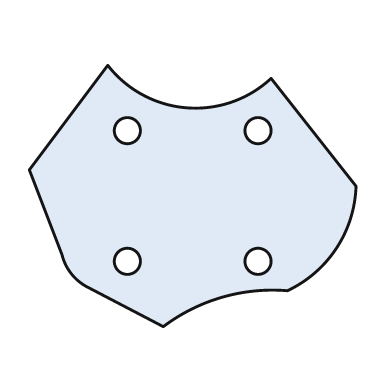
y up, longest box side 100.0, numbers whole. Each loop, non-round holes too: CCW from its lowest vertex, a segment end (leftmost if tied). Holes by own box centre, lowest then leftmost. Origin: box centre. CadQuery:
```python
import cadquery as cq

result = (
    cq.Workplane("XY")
    .moveTo(-9.0, -40.0)
    .threePointArc((9.0, -31.0), (29.0, -29.0))
    .threePointArc((44.0, -16.0), (50.0, 3.0))
    .lineTo(24.0, 36.0)
    .threePointArc((-2.0, 27.0), (-26.0, 40.0))
    .lineTo(-50.0, 8.0)
    .lineTo(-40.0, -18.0)
    .threePointArc((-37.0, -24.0), (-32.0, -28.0))
    .close()
    .moveTo(-20.0, -20.0)
    .circle(4.0)
    .moveTo(20.0, -20.0)
    .circle(4.0)
    .moveTo(-20.0, 20.0)
    .circle(4.0)
    .moveTo(20.0, 20.0)
    .circle(4.0)
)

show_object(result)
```